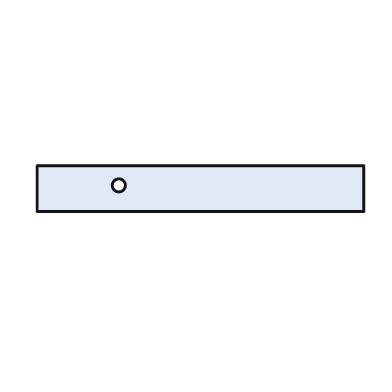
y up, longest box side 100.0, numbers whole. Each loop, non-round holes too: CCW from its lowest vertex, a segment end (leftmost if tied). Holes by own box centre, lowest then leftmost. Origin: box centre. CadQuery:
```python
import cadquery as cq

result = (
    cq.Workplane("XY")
    .moveTo(-50.0, -7.0)
    .lineTo(50.0, -7.0)
    .lineTo(50.0, 7.0)
    .lineTo(-50.0, 7.0)
    .close()
    .moveTo(-25.0, 1.0)
    .circle(2.0)
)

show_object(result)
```